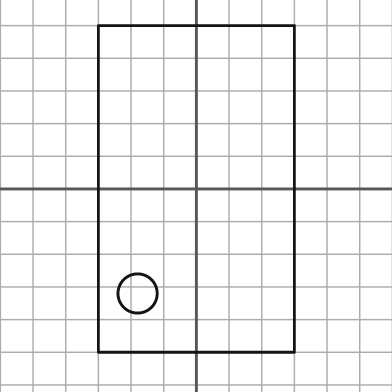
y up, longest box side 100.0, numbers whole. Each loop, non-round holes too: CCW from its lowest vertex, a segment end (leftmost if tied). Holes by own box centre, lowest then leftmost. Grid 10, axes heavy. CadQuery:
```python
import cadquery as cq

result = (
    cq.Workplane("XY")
    .moveTo(-30.0, -50.0)
    .lineTo(30.0, -50.0)
    .lineTo(30.0, 50.0)
    .lineTo(-30.0, 50.0)
    .close()
    .moveTo(-18.0, -32.0)
    .circle(6.0)
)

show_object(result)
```